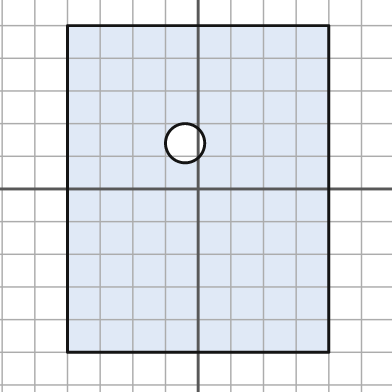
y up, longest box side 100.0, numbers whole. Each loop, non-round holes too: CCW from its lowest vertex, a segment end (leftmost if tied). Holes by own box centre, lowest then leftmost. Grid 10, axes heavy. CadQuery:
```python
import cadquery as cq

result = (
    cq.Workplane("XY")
    .moveTo(-40.0, -50.0)
    .lineTo(40.0, -50.0)
    .lineTo(40.0, 50.0)
    .lineTo(-40.0, 50.0)
    .close()
    .moveTo(-4.0, 14.0)
    .circle(6.0)
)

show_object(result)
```